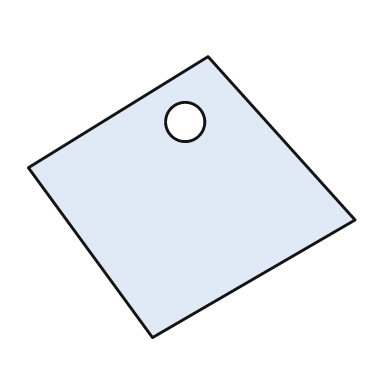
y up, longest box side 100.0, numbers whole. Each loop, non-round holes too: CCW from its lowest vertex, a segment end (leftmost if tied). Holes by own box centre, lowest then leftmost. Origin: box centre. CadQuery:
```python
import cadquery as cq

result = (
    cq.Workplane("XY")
    .moveTo(-12.0, -43.0)
    .lineTo(50.0, -7.0)
    .lineTo(5.0, 43.0)
    .lineTo(-50.0, 9.0)
    .close()
    .moveTo(-2.0, 23.0)
    .circle(6.0)
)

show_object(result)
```